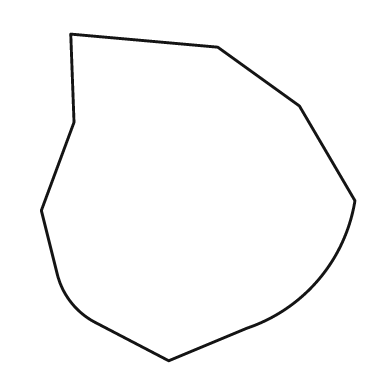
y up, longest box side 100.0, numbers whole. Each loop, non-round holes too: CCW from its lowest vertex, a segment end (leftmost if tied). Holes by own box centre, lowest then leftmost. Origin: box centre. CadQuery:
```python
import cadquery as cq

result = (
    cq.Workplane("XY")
    .moveTo(-9.0, -50.0)
    .lineTo(15.0, -40.0)
    .threePointArc((37.0, -25.0), (48.0, -1.0))
    .lineTo(31.0, 28.0)
    .lineTo(6.0, 46.0)
    .lineTo(-39.0, 50.0)
    .lineTo(-38.0, 23.0)
    .lineTo(-48.0, -4.0)
    .lineTo(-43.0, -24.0)
    .threePointArc((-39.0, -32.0), (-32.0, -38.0))
    .close()
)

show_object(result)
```